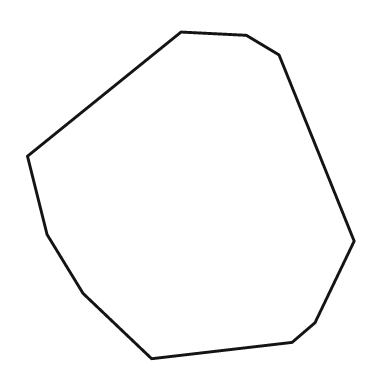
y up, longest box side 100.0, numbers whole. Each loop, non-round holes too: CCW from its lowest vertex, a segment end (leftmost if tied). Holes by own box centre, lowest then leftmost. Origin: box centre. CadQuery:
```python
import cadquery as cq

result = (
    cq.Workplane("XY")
    .moveTo(-12.0, -50.0)
    .lineTo(31.0, -45.0)
    .lineTo(38.0, -39.0)
    .lineTo(50.0, -14.0)
    .lineTo(27.0, 43.0)
    .lineTo(17.0, 49.0)
    .lineTo(-3.0, 50.0)
    .lineTo(-50.0, 12.0)
    .lineTo(-44.0, -12.0)
    .lineTo(-33.0, -30.0)
    .close()
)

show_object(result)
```